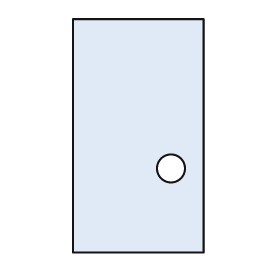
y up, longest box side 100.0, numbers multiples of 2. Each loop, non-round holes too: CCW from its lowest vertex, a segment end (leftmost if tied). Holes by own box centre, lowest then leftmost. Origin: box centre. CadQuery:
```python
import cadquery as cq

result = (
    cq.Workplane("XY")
    .moveTo(-28.0, -50.0)
    .lineTo(28.0, -50.0)
    .lineTo(28.0, 50.0)
    .lineTo(-28.0, 50.0)
    .close()
    .moveTo(14.0, -14.0)
    .circle(6.0)
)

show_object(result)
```